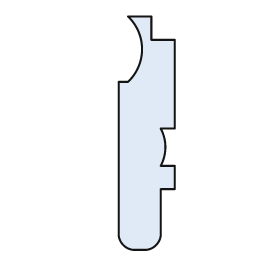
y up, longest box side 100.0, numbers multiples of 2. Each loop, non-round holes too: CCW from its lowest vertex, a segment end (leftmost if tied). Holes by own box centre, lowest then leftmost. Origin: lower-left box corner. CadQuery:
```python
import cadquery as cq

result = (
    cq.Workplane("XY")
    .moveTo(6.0, 0.0)
    .lineTo(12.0, 0.0)
    .threePointArc((16.0, 2.0), (18.0, 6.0))
    .lineTo(18.0, 26.0)
    .lineTo(24.0, 26.0)
    .lineTo(24.0, 36.0)
    .lineTo(18.0, 36.0)
    .threePointArc((20.0, 44.0), (18.0, 52.0))
    .lineTo(24.0, 52.0)
    .lineTo(24.0, 90.0)
    .lineTo(14.0, 90.0)
    .lineTo(14.0, 100.0)
    .lineTo(4.0, 100.0)
    .threePointArc((10.0, 86.0), (4.0, 72.0))
    .lineTo(0.0, 72.0)
    .lineTo(0.0, 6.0)
    .threePointArc((2.0, 2.0), (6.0, 0.0))
    .close()
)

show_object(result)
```